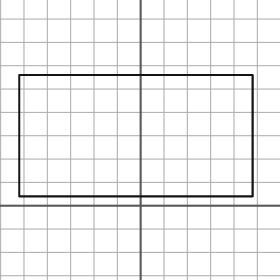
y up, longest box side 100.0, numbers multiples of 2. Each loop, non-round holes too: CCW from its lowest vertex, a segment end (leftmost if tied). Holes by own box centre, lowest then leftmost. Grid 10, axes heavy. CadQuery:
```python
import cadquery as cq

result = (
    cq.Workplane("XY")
    .moveTo(-52.0, 4.0)
    .lineTo(48.0, 4.0)
    .lineTo(48.0, 56.0)
    .lineTo(-52.0, 56.0)
    .close()
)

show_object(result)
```